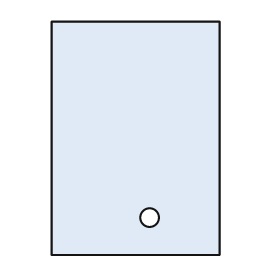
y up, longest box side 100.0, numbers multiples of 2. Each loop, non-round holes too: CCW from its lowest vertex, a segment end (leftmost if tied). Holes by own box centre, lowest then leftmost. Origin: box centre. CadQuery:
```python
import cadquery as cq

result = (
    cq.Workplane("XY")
    .moveTo(-36.0, -50.0)
    .lineTo(36.0, -50.0)
    .lineTo(36.0, 50.0)
    .lineTo(-36.0, 50.0)
    .close()
    .moveTo(6.0, -34.0)
    .circle(4.0)
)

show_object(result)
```